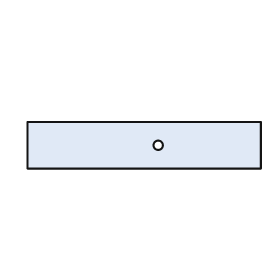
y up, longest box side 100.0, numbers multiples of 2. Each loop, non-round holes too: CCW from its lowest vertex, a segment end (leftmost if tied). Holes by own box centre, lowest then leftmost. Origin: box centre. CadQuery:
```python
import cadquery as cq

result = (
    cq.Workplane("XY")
    .moveTo(-50.0, -10.0)
    .lineTo(50.0, -10.0)
    .lineTo(50.0, 10.0)
    .lineTo(-50.0, 10.0)
    .close()
    .moveTo(6.0, 0.0)
    .circle(2.0)
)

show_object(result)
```